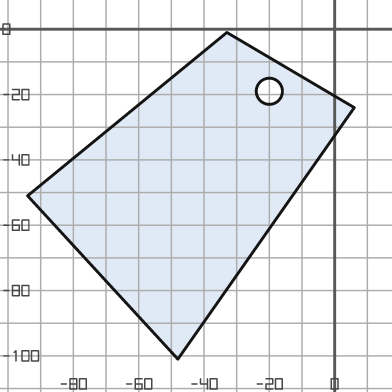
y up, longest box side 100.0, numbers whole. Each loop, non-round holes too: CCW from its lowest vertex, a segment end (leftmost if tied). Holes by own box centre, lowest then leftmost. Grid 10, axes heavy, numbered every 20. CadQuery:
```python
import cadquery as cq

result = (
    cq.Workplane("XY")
    .moveTo(-48.0, -101.0)
    .lineTo(6.0, -24.0)
    .lineTo(-33.0, -1.0)
    .lineTo(-94.0, -51.0)
    .close()
    .moveTo(-20.0, -19.0)
    .circle(4.0)
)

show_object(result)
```